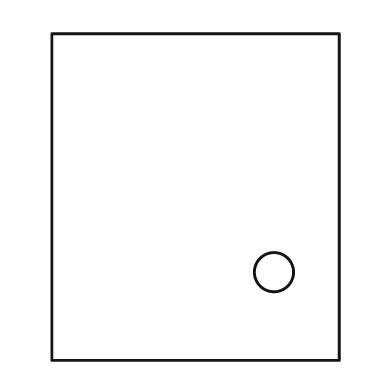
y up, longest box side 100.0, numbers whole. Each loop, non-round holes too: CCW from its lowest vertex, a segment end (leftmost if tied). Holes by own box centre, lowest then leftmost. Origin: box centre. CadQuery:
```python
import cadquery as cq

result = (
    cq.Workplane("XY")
    .moveTo(-44.0, -50.0)
    .lineTo(44.0, -50.0)
    .lineTo(44.0, 50.0)
    .lineTo(-44.0, 50.0)
    .close()
    .moveTo(24.0, -23.0)
    .circle(6.0)
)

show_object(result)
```